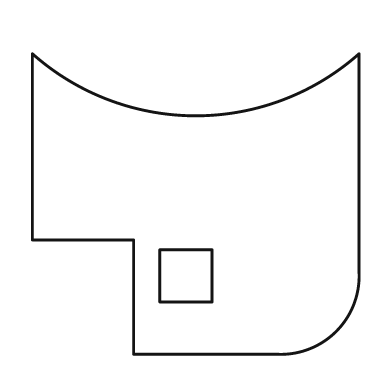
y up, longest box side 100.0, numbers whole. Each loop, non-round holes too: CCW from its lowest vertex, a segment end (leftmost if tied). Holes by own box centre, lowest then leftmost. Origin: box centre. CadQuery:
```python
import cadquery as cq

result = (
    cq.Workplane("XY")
    .moveTo(-19.0, -46.0)
    .lineTo(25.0, -46.0)
    .threePointArc((43.0, -39.0), (50.0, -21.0))
    .lineTo(50.0, 46.0)
    .threePointArc((0.0, 27.0), (-50.0, 46.0))
    .lineTo(-50.0, -11.0)
    .lineTo(-19.0, -11.0)
    .close()
    .moveTo(-11.0, -30.0)
    .lineTo(5.0, -30.0)
    .lineTo(5.0, -14.0)
    .lineTo(-11.0, -14.0)
    .close()
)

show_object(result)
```